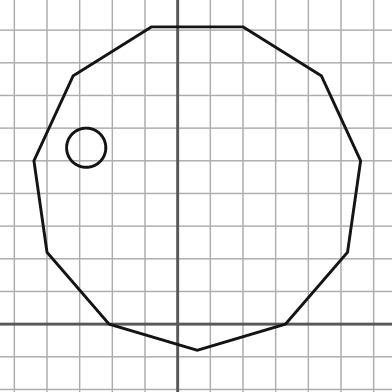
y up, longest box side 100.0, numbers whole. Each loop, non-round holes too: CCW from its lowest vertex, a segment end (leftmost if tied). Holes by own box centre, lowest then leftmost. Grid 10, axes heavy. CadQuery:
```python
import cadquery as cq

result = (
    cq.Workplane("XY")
    .moveTo(6.0, -8.0)
    .lineTo(33.0, 0.0)
    .lineTo(52.0, 22.0)
    .lineTo(56.0, 50.0)
    .lineTo(44.0, 76.0)
    .lineTo(20.0, 91.0)
    .lineTo(-8.0, 91.0)
    .lineTo(-32.0, 76.0)
    .lineTo(-44.0, 50.0)
    .lineTo(-40.0, 22.0)
    .lineTo(-21.0, 0.0)
    .close()
    .moveTo(-28.0, 54.0)
    .circle(6.0)
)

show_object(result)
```